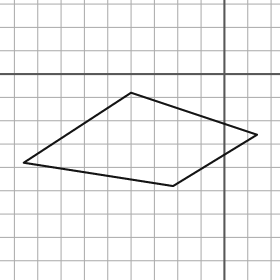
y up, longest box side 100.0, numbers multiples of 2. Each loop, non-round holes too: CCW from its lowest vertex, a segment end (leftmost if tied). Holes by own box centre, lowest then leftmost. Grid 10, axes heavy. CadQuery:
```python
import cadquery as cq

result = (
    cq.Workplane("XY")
    .moveTo(-22.0, -48.0)
    .lineTo(14.0, -26.0)
    .lineTo(-40.0, -8.0)
    .lineTo(-86.0, -38.0)
    .close()
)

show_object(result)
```